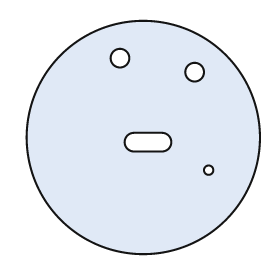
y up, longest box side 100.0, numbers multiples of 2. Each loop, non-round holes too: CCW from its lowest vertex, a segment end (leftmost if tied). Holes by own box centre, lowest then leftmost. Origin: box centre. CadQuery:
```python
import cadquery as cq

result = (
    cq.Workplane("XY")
    .moveTo(0.0, 0.0)
    .circle(50.0)
    .moveTo(28.0, -14.0)
    .circle(2.0)
    .moveTo(-4.0, -6.0)
    .lineTo(8.0, -6.0)
    .threePointArc((12.0, -2.0), (8.0, 2.0))
    .lineTo(-4.0, 2.0)
    .threePointArc((-8.0, -2.0), (-4.0, -6.0))
    .close()
    .moveTo(22.0, 28.0)
    .circle(4.0)
    .moveTo(-10.0, 34.0)
    .circle(4.0)
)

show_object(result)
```